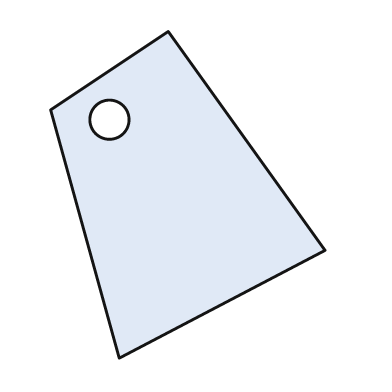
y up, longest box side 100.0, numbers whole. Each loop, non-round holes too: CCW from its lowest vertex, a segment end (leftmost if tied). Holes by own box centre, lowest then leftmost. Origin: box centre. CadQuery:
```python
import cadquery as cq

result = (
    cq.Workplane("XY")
    .moveTo(-21.0, -50.0)
    .lineTo(42.0, -17.0)
    .lineTo(-6.0, 50.0)
    .lineTo(-42.0, 26.0)
    .close()
    .moveTo(-24.0, 23.0)
    .circle(6.0)
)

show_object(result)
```